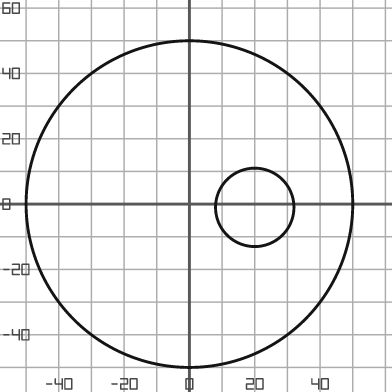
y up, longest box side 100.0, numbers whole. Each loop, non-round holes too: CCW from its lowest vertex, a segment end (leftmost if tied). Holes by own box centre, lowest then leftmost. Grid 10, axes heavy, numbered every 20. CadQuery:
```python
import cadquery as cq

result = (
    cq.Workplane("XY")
    .moveTo(0.0, 0.0)
    .circle(50.0)
    .moveTo(20.0, -1.0)
    .circle(12.0)
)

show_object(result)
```